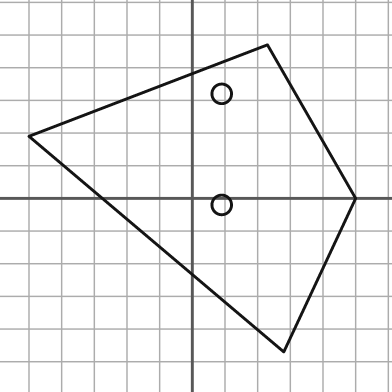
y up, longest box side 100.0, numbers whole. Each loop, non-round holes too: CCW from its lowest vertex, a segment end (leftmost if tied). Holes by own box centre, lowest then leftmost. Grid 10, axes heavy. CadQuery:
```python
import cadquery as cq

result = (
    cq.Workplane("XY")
    .moveTo(28.0, -47.0)
    .lineTo(50.0, 0.0)
    .lineTo(23.0, 47.0)
    .lineTo(-50.0, 19.0)
    .close()
    .moveTo(9.0, -2.0)
    .circle(3.0)
    .moveTo(9.0, 32.0)
    .circle(3.0)
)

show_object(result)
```